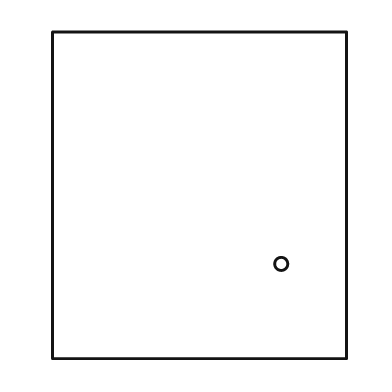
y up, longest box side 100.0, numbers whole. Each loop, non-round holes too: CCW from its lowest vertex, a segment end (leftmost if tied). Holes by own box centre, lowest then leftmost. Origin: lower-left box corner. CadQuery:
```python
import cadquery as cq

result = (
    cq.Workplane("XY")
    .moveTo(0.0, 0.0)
    .lineTo(90.0, 0.0)
    .lineTo(90.0, 100.0)
    .lineTo(0.0, 100.0)
    .close()
    .moveTo(70.0, 29.0)
    .circle(2.0)
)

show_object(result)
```